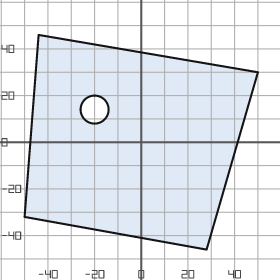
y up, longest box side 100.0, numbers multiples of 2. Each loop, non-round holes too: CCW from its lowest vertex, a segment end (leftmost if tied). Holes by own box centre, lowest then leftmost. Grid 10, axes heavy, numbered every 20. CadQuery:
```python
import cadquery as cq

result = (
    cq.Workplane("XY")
    .moveTo(28.0, -46.0)
    .lineTo(50.0, 30.0)
    .lineTo(-44.0, 46.0)
    .lineTo(-50.0, -32.0)
    .close()
    .moveTo(-20.0, 14.0)
    .circle(6.0)
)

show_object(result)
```